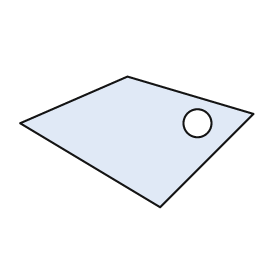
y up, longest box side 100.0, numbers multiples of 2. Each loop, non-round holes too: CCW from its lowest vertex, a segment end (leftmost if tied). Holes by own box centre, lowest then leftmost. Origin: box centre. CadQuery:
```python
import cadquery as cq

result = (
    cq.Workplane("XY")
    .moveTo(10.0, -28.0)
    .lineTo(50.0, 12.0)
    .lineTo(-4.0, 28.0)
    .lineTo(-50.0, 8.0)
    .close()
    .moveTo(26.0, 8.0)
    .circle(6.0)
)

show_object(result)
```